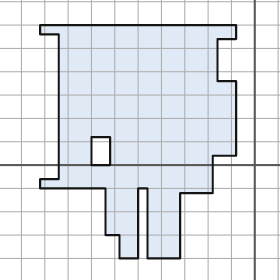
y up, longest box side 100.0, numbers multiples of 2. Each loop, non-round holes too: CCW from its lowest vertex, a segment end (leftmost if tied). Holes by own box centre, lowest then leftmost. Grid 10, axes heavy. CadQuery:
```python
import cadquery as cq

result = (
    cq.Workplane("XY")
    .moveTo(-58.0, -40.0)
    .lineTo(-50.0, -40.0)
    .lineTo(-50.0, -10.0)
    .lineTo(-46.0, -10.0)
    .lineTo(-46.0, -40.0)
    .lineTo(-32.0, -40.0)
    .lineTo(-32.0, -12.0)
    .lineTo(-18.0, -12.0)
    .lineTo(-18.0, 4.0)
    .lineTo(-8.0, 4.0)
    .lineTo(-8.0, 36.0)
    .lineTo(-16.0, 36.0)
    .lineTo(-16.0, 54.0)
    .lineTo(-8.0, 54.0)
    .lineTo(-8.0, 60.0)
    .lineTo(-92.0, 60.0)
    .lineTo(-92.0, 56.0)
    .lineTo(-84.0, 56.0)
    .lineTo(-84.0, -6.0)
    .lineTo(-92.0, -6.0)
    .lineTo(-92.0, -10.0)
    .lineTo(-64.0, -10.0)
    .lineTo(-64.0, -30.0)
    .lineTo(-58.0, -30.0)
    .close()
    .moveTo(-70.0, 0.0)
    .lineTo(-62.0, 0.0)
    .lineTo(-62.0, 12.0)
    .lineTo(-70.0, 12.0)
    .close()
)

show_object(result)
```